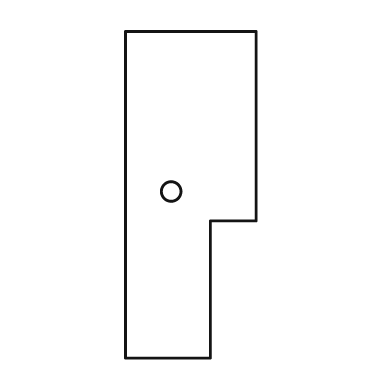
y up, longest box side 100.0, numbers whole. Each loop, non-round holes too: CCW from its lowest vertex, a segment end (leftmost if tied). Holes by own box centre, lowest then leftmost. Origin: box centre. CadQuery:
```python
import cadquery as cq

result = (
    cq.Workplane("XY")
    .moveTo(-20.0, -50.0)
    .lineTo(6.0, -50.0)
    .lineTo(6.0, -8.0)
    .lineTo(20.0, -8.0)
    .lineTo(20.0, 50.0)
    .lineTo(-20.0, 50.0)
    .close()
    .moveTo(-6.0, 1.0)
    .circle(3.0)
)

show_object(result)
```